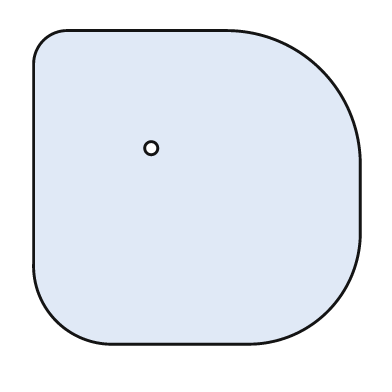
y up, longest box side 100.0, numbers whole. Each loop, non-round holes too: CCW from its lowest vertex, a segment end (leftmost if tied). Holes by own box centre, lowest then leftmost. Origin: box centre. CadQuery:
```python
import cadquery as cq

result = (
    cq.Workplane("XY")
    .moveTo(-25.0, -48.0)
    .lineTo(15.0, -48.0)
    .threePointArc((40.0, -38.0), (50.0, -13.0))
    .lineTo(50.0, 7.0)
    .threePointArc((38.0, 36.0), (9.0, 48.0))
    .lineTo(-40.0, 48.0)
    .threePointArc((-47.0, 45.0), (-50.0, 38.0))
    .lineTo(-50.0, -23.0)
    .threePointArc((-43.0, -41.0), (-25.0, -48.0))
    .close()
    .moveTo(-14.0, 12.0)
    .circle(2.0)
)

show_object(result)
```